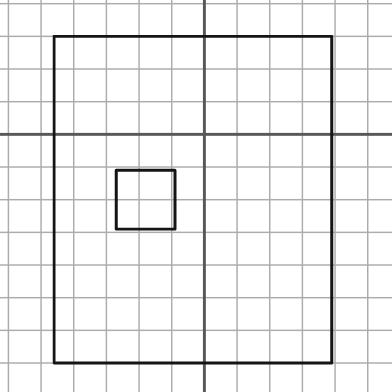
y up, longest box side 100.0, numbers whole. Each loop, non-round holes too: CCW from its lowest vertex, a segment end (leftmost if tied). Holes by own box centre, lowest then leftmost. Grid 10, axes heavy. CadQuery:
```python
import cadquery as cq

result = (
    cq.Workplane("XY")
    .moveTo(-46.0, -70.0)
    .lineTo(39.0, -70.0)
    .lineTo(39.0, 30.0)
    .lineTo(-46.0, 30.0)
    .close()
    .moveTo(-27.0, -29.0)
    .lineTo(-9.0, -29.0)
    .lineTo(-9.0, -11.0)
    .lineTo(-27.0, -11.0)
    .close()
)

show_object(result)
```